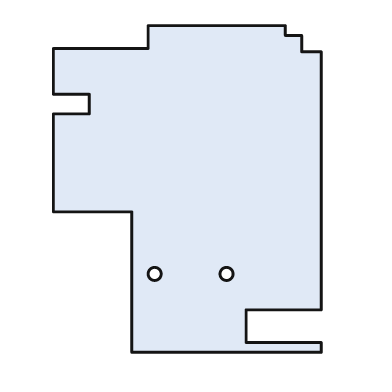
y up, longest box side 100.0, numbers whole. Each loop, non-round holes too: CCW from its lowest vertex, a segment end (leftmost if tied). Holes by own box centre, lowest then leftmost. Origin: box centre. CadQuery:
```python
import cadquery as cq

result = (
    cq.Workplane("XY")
    .moveTo(-17.0, -50.0)
    .lineTo(41.0, -50.0)
    .lineTo(41.0, -47.0)
    .lineTo(18.0, -47.0)
    .lineTo(18.0, -37.0)
    .lineTo(41.0, -37.0)
    .lineTo(41.0, 42.0)
    .lineTo(35.0, 42.0)
    .lineTo(35.0, 47.0)
    .lineTo(30.0, 47.0)
    .lineTo(30.0, 50.0)
    .lineTo(-12.0, 50.0)
    .lineTo(-12.0, 43.0)
    .lineTo(-41.0, 43.0)
    .lineTo(-41.0, 29.0)
    .lineTo(-30.0, 29.0)
    .lineTo(-30.0, 23.0)
    .lineTo(-41.0, 23.0)
    .lineTo(-41.0, -7.0)
    .lineTo(-17.0, -7.0)
    .close()
    .moveTo(-10.0, -26.0)
    .circle(2.0)
    .moveTo(12.0, -26.0)
    .circle(2.0)
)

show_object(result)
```